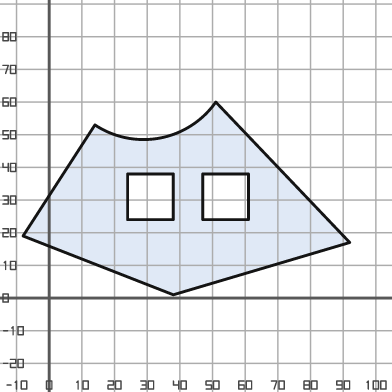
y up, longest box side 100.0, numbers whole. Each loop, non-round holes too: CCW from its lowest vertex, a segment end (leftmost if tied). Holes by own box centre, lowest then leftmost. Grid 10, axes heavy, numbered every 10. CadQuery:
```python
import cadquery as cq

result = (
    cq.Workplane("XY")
    .moveTo(38.0, 1.0)
    .lineTo(92.0, 17.0)
    .lineTo(51.0, 60.0)
    .threePointArc((34.0, 49.0), (14.0, 53.0))
    .lineTo(-8.0, 19.0)
    .close()
    .moveTo(24.0, 24.0)
    .lineTo(38.0, 24.0)
    .lineTo(38.0, 38.0)
    .lineTo(24.0, 38.0)
    .close()
    .moveTo(47.0, 24.0)
    .lineTo(61.0, 24.0)
    .lineTo(61.0, 38.0)
    .lineTo(47.0, 38.0)
    .close()
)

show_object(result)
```